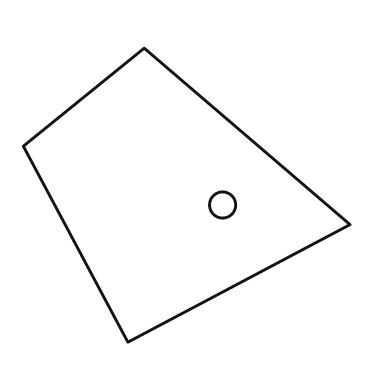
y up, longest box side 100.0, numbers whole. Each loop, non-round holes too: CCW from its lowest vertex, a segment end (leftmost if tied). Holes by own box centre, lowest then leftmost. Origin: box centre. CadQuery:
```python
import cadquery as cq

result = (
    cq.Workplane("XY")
    .moveTo(-18.0, -45.0)
    .lineTo(50.0, -9.0)
    .lineTo(-13.0, 45.0)
    .lineTo(-50.0, 15.0)
    .close()
    .moveTo(11.0, -3.0)
    .circle(4.0)
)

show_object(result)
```